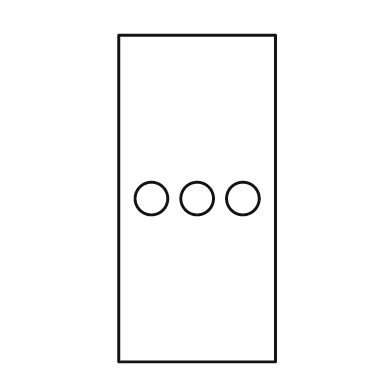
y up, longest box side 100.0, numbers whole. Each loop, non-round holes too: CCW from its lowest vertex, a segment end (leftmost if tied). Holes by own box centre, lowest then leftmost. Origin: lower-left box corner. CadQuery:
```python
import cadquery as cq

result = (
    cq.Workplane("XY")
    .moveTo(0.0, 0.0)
    .lineTo(48.0, 0.0)
    .lineTo(48.0, 100.0)
    .lineTo(0.0, 100.0)
    .close()
    .moveTo(10.0, 50.0)
    .circle(5.0)
    .moveTo(24.0, 50.0)
    .circle(5.0)
    .moveTo(38.0, 50.0)
    .circle(5.0)
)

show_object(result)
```